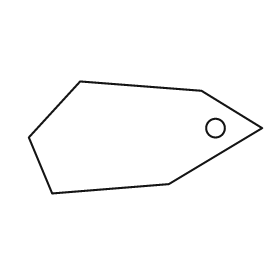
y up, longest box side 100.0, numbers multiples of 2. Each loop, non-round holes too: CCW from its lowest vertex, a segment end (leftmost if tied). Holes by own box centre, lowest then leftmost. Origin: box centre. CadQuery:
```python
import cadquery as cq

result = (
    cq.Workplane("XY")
    .moveTo(-40.0, -24.0)
    .lineTo(10.0, -20.0)
    .lineTo(50.0, 4.0)
    .lineTo(24.0, 20.0)
    .lineTo(-28.0, 24.0)
    .lineTo(-50.0, 0.0)
    .close()
    .moveTo(30.0, 4.0)
    .circle(4.0)
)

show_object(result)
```